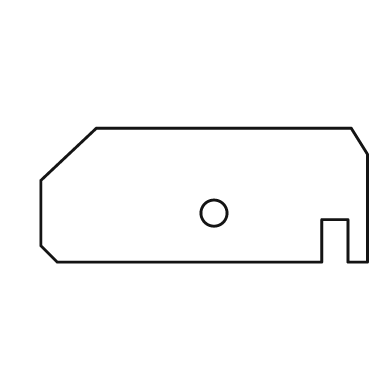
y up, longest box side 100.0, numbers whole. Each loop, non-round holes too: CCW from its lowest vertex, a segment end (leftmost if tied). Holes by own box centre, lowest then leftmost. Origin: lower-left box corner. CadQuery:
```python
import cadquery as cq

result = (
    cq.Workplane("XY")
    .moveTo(5.0, 0.0)
    .lineTo(86.0, 0.0)
    .lineTo(86.0, 13.0)
    .lineTo(94.0, 13.0)
    .lineTo(94.0, 0.0)
    .lineTo(100.0, 0.0)
    .lineTo(100.0, 33.0)
    .lineTo(95.0, 41.0)
    .lineTo(17.0, 41.0)
    .lineTo(0.0, 25.0)
    .lineTo(0.0, 5.0)
    .close()
    .moveTo(53.0, 15.0)
    .circle(4.0)
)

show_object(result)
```